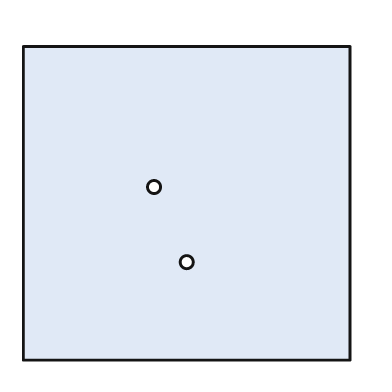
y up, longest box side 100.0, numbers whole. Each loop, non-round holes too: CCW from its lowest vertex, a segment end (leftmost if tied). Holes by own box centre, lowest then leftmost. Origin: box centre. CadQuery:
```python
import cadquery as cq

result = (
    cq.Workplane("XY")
    .moveTo(-50.0, -48.0)
    .lineTo(50.0, -48.0)
    .lineTo(50.0, 48.0)
    .lineTo(-50.0, 48.0)
    .close()
    .moveTo(0.0, -18.0)
    .circle(2.0)
    .moveTo(-10.0, 5.0)
    .circle(2.0)
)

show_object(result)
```